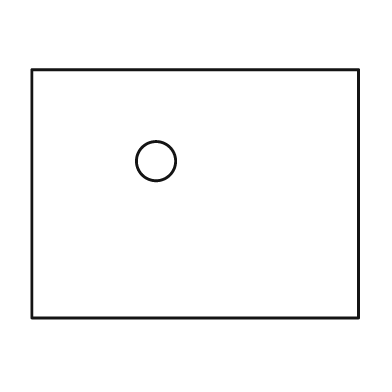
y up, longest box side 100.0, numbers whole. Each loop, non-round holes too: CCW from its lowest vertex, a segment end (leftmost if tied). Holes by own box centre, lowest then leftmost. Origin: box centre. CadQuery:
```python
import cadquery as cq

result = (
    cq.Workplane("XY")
    .moveTo(-50.0, -38.0)
    .lineTo(50.0, -38.0)
    .lineTo(50.0, 38.0)
    .lineTo(-50.0, 38.0)
    .close()
    .moveTo(-12.0, 10.0)
    .circle(6.0)
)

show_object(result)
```